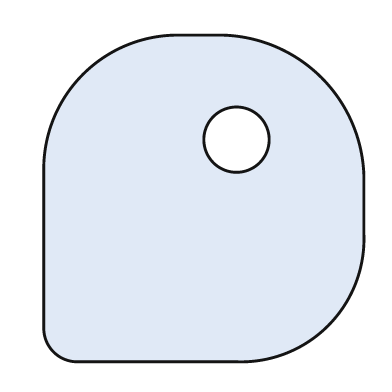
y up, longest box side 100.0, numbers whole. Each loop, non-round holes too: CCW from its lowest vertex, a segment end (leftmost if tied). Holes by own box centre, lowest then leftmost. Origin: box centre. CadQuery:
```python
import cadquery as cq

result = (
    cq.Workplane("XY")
    .moveTo(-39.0, -50.0)
    .lineTo(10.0, -50.0)
    .threePointArc((38.0, -39.0), (49.0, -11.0))
    .lineTo(49.0, 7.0)
    .threePointArc((36.0, 37.0), (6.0, 50.0))
    .lineTo(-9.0, 50.0)
    .threePointArc((-37.0, 38.0), (-49.0, 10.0))
    .lineTo(-49.0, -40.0)
    .threePointArc((-46.0, -47.0), (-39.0, -50.0))
    .close()
    .moveTo(10.0, 18.0)
    .circle(10.0)
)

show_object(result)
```